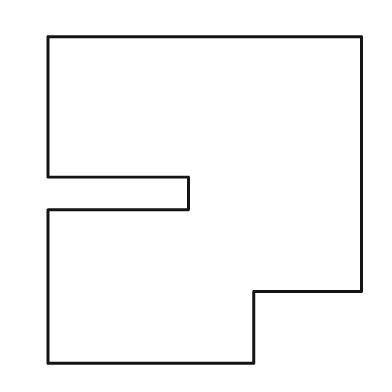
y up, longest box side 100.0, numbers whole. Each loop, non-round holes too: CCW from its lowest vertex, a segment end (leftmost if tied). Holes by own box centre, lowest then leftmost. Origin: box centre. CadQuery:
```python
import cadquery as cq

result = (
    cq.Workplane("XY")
    .moveTo(-48.0, -50.0)
    .lineTo(15.0, -50.0)
    .lineTo(15.0, -28.0)
    .lineTo(48.0, -28.0)
    .lineTo(48.0, 50.0)
    .lineTo(-48.0, 50.0)
    .lineTo(-48.0, 7.0)
    .lineTo(-5.0, 7.0)
    .lineTo(-5.0, -3.0)
    .lineTo(-48.0, -3.0)
    .close()
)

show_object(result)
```